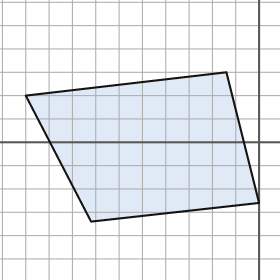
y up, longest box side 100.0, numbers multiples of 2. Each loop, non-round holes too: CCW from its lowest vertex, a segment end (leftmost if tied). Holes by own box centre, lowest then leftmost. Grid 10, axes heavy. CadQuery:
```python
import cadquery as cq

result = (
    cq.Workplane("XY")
    .moveTo(-72.0, -34.0)
    .lineTo(0.0, -26.0)
    .lineTo(-14.0, 30.0)
    .lineTo(-100.0, 20.0)
    .close()
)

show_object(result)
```